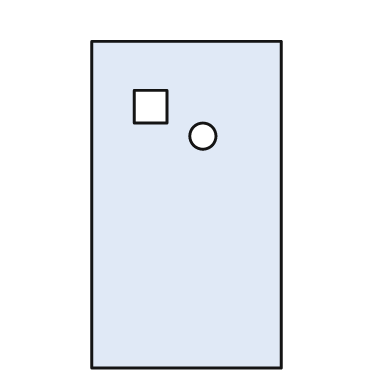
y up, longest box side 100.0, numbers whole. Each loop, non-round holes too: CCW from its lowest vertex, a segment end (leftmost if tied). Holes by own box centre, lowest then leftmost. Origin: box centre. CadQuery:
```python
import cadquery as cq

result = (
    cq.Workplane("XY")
    .moveTo(-29.0, -50.0)
    .lineTo(29.0, -50.0)
    .lineTo(29.0, 50.0)
    .lineTo(-29.0, 50.0)
    .close()
    .moveTo(5.0, 21.0)
    .circle(4.0)
    .moveTo(-16.0, 25.0)
    .lineTo(-6.0, 25.0)
    .lineTo(-6.0, 35.0)
    .lineTo(-16.0, 35.0)
    .close()
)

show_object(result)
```